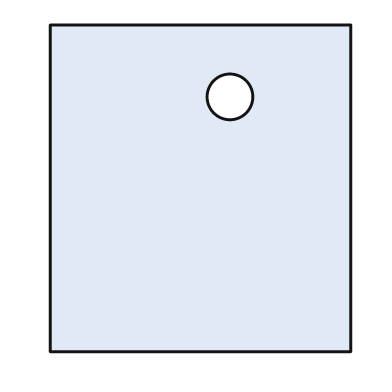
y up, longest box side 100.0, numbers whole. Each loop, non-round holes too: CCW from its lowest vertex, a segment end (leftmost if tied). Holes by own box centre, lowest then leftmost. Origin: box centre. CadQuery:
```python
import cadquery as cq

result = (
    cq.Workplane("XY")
    .moveTo(-46.0, -50.0)
    .lineTo(46.0, -50.0)
    .lineTo(46.0, 50.0)
    .lineTo(-46.0, 50.0)
    .close()
    .moveTo(9.0, 28.0)
    .circle(7.0)
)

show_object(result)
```